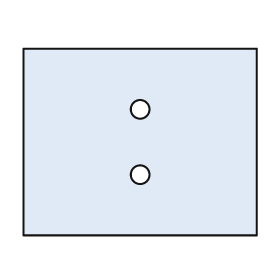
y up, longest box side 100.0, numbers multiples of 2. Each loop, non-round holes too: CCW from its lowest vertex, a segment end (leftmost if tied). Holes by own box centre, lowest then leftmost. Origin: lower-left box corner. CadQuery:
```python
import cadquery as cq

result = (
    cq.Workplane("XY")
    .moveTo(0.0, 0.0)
    .lineTo(100.0, 0.0)
    .lineTo(100.0, 80.0)
    .lineTo(0.0, 80.0)
    .close()
    .moveTo(50.0, 26.0)
    .circle(4.0)
    .moveTo(50.0, 54.0)
    .circle(4.0)
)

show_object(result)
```